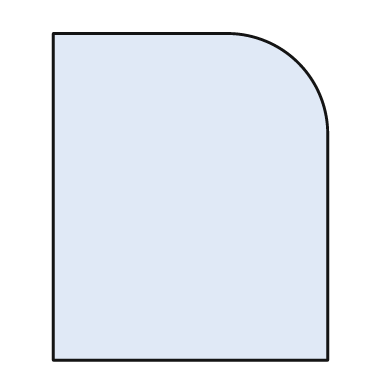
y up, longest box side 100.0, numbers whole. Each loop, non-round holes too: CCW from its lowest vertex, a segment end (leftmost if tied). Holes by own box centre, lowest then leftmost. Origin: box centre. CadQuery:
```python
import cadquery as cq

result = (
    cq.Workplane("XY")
    .moveTo(-42.0, -50.0)
    .lineTo(42.0, -50.0)
    .lineTo(42.0, 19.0)
    .threePointArc((33.0, 41.0), (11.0, 50.0))
    .lineTo(-42.0, 50.0)
    .close()
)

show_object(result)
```